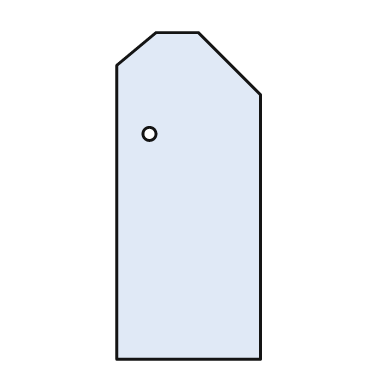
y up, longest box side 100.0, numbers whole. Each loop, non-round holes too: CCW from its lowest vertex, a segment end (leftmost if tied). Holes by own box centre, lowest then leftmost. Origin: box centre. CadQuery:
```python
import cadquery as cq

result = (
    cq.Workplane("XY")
    .moveTo(-22.0, -50.0)
    .lineTo(22.0, -50.0)
    .lineTo(22.0, 31.0)
    .lineTo(3.0, 50.0)
    .lineTo(-10.0, 50.0)
    .lineTo(-22.0, 40.0)
    .close()
    .moveTo(-12.0, 19.0)
    .circle(2.0)
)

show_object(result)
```